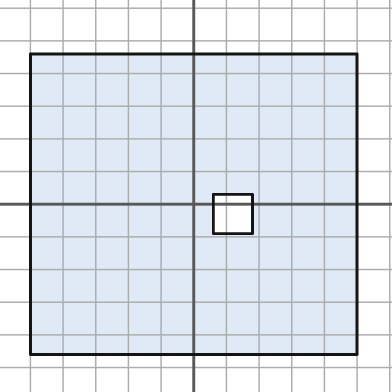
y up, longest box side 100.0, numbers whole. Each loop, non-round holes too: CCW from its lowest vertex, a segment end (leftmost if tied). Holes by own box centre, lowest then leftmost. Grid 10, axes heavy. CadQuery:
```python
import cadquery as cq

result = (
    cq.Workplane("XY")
    .moveTo(-50.0, -46.0)
    .lineTo(50.0, -46.0)
    .lineTo(50.0, 46.0)
    .lineTo(-50.0, 46.0)
    .close()
    .moveTo(6.0, -9.0)
    .lineTo(18.0, -9.0)
    .lineTo(18.0, 3.0)
    .lineTo(6.0, 3.0)
    .close()
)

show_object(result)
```